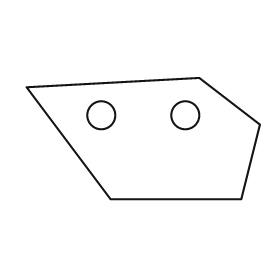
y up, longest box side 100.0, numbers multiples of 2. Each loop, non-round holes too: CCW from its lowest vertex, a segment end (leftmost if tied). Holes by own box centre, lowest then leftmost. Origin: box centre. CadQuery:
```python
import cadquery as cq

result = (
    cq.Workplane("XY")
    .moveTo(-14.0, -26.0)
    .lineTo(42.0, -26.0)
    .lineTo(50.0, 6.0)
    .lineTo(24.0, 26.0)
    .lineTo(-50.0, 22.0)
    .close()
    .moveTo(-18.0, 10.0)
    .circle(6.0)
    .moveTo(18.0, 10.0)
    .circle(6.0)
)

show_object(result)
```